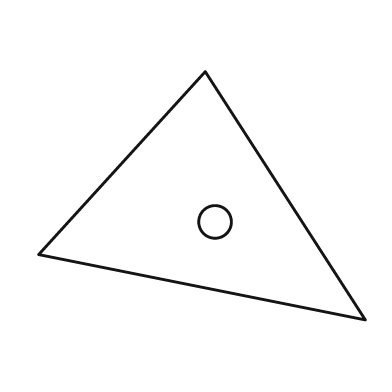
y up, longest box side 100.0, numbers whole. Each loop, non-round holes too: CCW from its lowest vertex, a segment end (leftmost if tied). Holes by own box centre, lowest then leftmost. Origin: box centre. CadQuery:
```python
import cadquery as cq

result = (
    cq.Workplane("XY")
    .moveTo(50.0, -38.0)
    .lineTo(1.0, 38.0)
    .lineTo(-50.0, -18.0)
    .close()
    .moveTo(4.0, -8.0)
    .circle(5.0)
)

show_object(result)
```